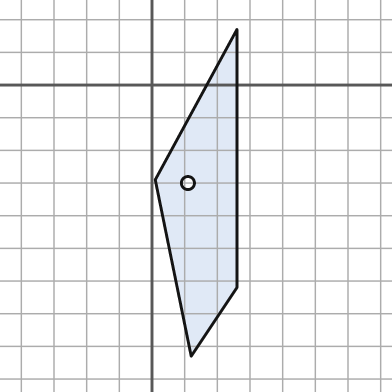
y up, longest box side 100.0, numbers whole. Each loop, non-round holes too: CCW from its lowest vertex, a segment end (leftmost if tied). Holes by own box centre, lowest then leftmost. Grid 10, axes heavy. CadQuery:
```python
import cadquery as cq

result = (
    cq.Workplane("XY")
    .moveTo(12.0, -83.0)
    .lineTo(26.0, -62.0)
    .lineTo(26.0, 17.0)
    .lineTo(1.0, -29.0)
    .close()
    .moveTo(11.0, -30.0)
    .circle(2.0)
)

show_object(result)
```